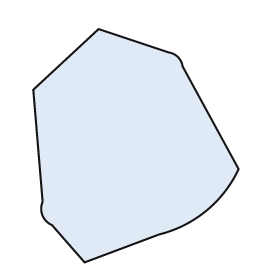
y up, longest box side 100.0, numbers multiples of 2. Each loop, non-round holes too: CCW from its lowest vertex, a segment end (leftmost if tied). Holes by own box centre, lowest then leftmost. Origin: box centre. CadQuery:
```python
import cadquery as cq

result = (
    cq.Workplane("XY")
    .moveTo(-22.0, -50.0)
    .lineTo(10.0, -38.0)
    .threePointArc((30.0, -28.0), (44.0, -10.0))
    .lineTo(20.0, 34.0)
    .threePointArc((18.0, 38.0), (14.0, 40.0))
    .lineTo(-16.0, 50.0)
    .lineTo(-44.0, 24.0)
    .lineTo(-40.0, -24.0)
    .threePointArc((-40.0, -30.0), (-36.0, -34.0))
    .close()
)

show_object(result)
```